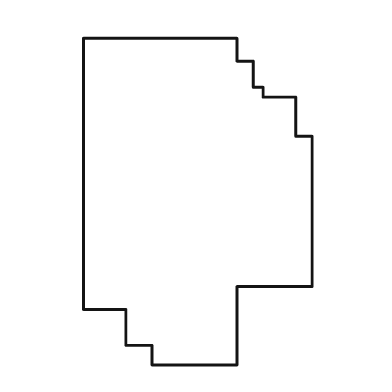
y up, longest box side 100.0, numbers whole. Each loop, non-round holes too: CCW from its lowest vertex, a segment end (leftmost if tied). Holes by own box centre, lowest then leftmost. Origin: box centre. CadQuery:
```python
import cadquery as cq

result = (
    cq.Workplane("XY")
    .moveTo(-14.0, -50.0)
    .lineTo(12.0, -50.0)
    .lineTo(12.0, -26.0)
    .lineTo(35.0, -26.0)
    .lineTo(35.0, 20.0)
    .lineTo(30.0, 20.0)
    .lineTo(30.0, 32.0)
    .lineTo(20.0, 32.0)
    .lineTo(20.0, 35.0)
    .lineTo(17.0, 35.0)
    .lineTo(17.0, 43.0)
    .lineTo(12.0, 43.0)
    .lineTo(12.0, 50.0)
    .lineTo(-35.0, 50.0)
    .lineTo(-35.0, -33.0)
    .lineTo(-22.0, -33.0)
    .lineTo(-22.0, -44.0)
    .lineTo(-14.0, -44.0)
    .close()
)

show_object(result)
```